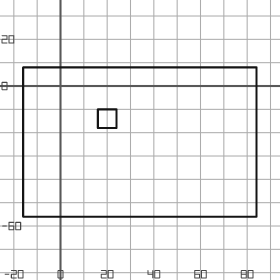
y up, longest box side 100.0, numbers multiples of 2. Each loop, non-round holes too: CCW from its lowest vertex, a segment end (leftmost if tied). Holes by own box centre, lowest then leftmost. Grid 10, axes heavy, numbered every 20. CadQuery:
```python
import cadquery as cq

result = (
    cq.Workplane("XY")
    .moveTo(-16.0, -56.0)
    .lineTo(84.0, -56.0)
    .lineTo(84.0, 8.0)
    .lineTo(-16.0, 8.0)
    .close()
    .moveTo(16.0, -18.0)
    .lineTo(24.0, -18.0)
    .lineTo(24.0, -10.0)
    .lineTo(16.0, -10.0)
    .close()
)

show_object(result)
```